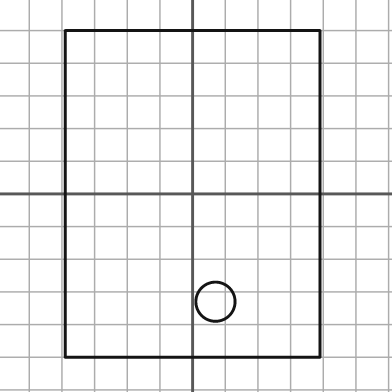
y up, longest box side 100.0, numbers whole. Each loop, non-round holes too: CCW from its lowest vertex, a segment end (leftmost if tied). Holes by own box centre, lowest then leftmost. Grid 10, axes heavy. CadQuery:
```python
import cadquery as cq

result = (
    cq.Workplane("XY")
    .moveTo(-39.0, -50.0)
    .lineTo(39.0, -50.0)
    .lineTo(39.0, 50.0)
    .lineTo(-39.0, 50.0)
    .close()
    .moveTo(7.0, -33.0)
    .circle(6.0)
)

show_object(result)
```